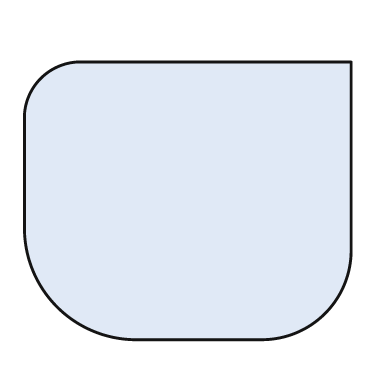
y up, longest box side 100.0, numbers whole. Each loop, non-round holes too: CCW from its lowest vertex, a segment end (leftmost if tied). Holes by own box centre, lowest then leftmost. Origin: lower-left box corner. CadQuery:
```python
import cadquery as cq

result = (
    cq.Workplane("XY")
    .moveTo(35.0, 0.0)
    .lineTo(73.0, 0.0)
    .threePointArc((92.0, 8.0), (100.0, 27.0))
    .lineTo(100.0, 85.0)
    .lineTo(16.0, 85.0)
    .threePointArc((5.0, 80.0), (0.0, 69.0))
    .lineTo(0.0, 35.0)
    .threePointArc((10.0, 10.0), (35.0, 0.0))
    .close()
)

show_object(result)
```